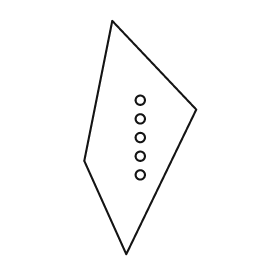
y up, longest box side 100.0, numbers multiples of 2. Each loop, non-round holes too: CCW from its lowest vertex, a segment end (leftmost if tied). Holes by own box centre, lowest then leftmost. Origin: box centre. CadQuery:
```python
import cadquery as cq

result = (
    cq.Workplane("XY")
    .moveTo(-6.0, -50.0)
    .lineTo(24.0, 12.0)
    .lineTo(-12.0, 50.0)
    .lineTo(-24.0, -10.0)
    .close()
    .moveTo(0.0, -16.0)
    .circle(2.0)
    .moveTo(0.0, -8.0)
    .circle(2.0)
    .moveTo(0.0, 0.0)
    .circle(2.0)
    .moveTo(0.0, 8.0)
    .circle(2.0)
    .moveTo(0.0, 16.0)
    .circle(2.0)
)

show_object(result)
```